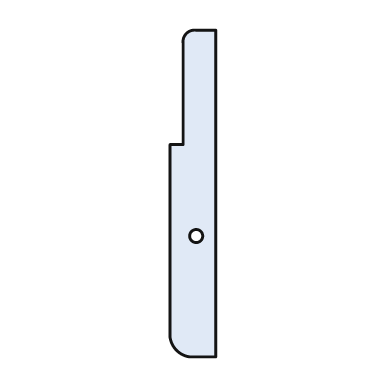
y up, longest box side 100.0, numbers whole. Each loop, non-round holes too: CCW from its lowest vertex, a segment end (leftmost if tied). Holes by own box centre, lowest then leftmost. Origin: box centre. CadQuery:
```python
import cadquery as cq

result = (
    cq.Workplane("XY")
    .moveTo(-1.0, -50.0)
    .lineTo(7.0, -50.0)
    .lineTo(7.0, 50.0)
    .lineTo(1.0, 50.0)
    .threePointArc((-2.0, 49.0), (-3.0, 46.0))
    .lineTo(-3.0, 15.0)
    .lineTo(-7.0, 15.0)
    .lineTo(-7.0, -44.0)
    .threePointArc((-5.0, -48.0), (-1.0, -50.0))
    .close()
    .moveTo(1.0, -13.0)
    .circle(2.0)
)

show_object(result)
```